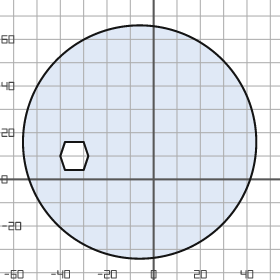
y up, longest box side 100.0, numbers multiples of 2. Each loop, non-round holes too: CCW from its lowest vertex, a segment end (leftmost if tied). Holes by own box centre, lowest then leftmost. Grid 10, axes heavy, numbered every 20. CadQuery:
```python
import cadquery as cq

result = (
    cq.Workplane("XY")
    .moveTo(-6.0, 16.0)
    .circle(50.0)
    .moveTo(-38.0, 4.0)
    .lineTo(-30.0, 4.0)
    .lineTo(-28.0, 10.0)
    .lineTo(-30.0, 16.0)
    .lineTo(-38.0, 16.0)
    .lineTo(-40.0, 10.0)
    .close()
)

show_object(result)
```